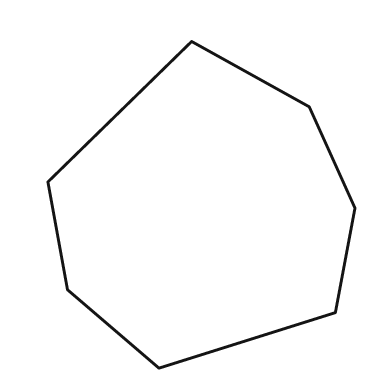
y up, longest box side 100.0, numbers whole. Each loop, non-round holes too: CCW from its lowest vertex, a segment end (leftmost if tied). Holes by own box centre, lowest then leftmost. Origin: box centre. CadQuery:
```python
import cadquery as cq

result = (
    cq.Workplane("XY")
    .moveTo(-13.0, -50.0)
    .lineTo(41.0, -33.0)
    .lineTo(47.0, -1.0)
    .lineTo(33.0, 30.0)
    .lineTo(-3.0, 50.0)
    .lineTo(-47.0, 7.0)
    .lineTo(-41.0, -26.0)
    .close()
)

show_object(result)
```